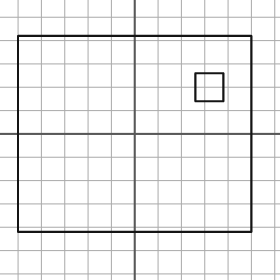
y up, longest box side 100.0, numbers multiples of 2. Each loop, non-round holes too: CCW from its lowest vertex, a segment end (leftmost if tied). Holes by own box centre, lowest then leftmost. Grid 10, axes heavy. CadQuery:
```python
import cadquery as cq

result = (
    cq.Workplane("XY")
    .moveTo(-50.0, -42.0)
    .lineTo(50.0, -42.0)
    .lineTo(50.0, 42.0)
    .lineTo(-50.0, 42.0)
    .close()
    .moveTo(26.0, 14.0)
    .lineTo(38.0, 14.0)
    .lineTo(38.0, 26.0)
    .lineTo(26.0, 26.0)
    .close()
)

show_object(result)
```